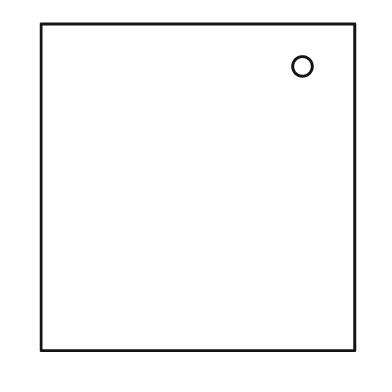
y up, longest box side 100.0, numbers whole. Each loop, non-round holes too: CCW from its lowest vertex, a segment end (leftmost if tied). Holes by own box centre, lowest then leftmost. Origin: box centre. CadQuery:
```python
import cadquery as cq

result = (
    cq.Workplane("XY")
    .moveTo(-48.0, -50.0)
    .lineTo(48.0, -50.0)
    .lineTo(48.0, 50.0)
    .lineTo(-48.0, 50.0)
    .close()
    .moveTo(32.0, 37.0)
    .circle(3.0)
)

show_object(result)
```